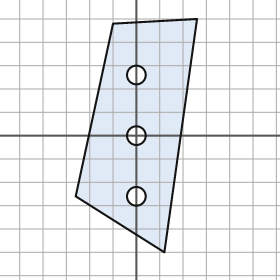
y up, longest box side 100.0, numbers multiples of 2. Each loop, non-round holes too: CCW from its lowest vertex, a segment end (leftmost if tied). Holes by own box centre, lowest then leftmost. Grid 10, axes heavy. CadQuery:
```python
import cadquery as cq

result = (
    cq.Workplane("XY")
    .moveTo(12.0, -50.0)
    .lineTo(26.0, 50.0)
    .lineTo(-10.0, 48.0)
    .lineTo(-26.0, -26.0)
    .close()
    .moveTo(0.0, -26.0)
    .circle(4.0)
    .moveTo(0.0, 0.0)
    .circle(4.0)
    .moveTo(0.0, 26.0)
    .circle(4.0)
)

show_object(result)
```